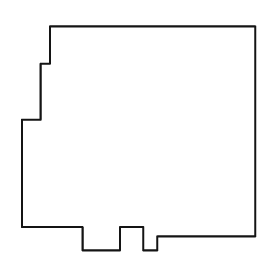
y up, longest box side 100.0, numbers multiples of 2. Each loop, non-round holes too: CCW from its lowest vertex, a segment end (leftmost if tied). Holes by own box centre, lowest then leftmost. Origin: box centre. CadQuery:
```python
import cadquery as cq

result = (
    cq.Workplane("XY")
    .moveTo(-24.0, -48.0)
    .lineTo(-8.0, -48.0)
    .lineTo(-8.0, -38.0)
    .lineTo(2.0, -38.0)
    .lineTo(2.0, -48.0)
    .lineTo(8.0, -48.0)
    .lineTo(8.0, -42.0)
    .lineTo(50.0, -42.0)
    .lineTo(50.0, 48.0)
    .lineTo(-38.0, 48.0)
    .lineTo(-38.0, 32.0)
    .lineTo(-42.0, 32.0)
    .lineTo(-42.0, 8.0)
    .lineTo(-50.0, 8.0)
    .lineTo(-50.0, -38.0)
    .lineTo(-24.0, -38.0)
    .close()
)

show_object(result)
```